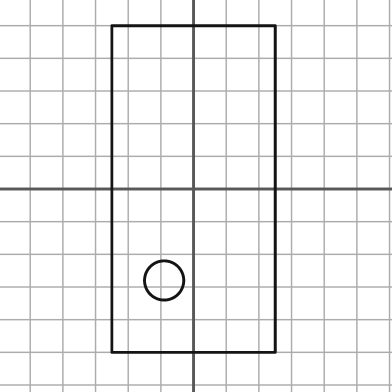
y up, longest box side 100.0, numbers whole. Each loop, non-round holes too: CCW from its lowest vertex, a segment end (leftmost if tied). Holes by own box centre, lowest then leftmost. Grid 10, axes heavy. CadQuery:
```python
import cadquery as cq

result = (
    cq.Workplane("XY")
    .moveTo(-25.0, -50.0)
    .lineTo(25.0, -50.0)
    .lineTo(25.0, 50.0)
    .lineTo(-25.0, 50.0)
    .close()
    .moveTo(-9.0, -28.0)
    .circle(6.0)
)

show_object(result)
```